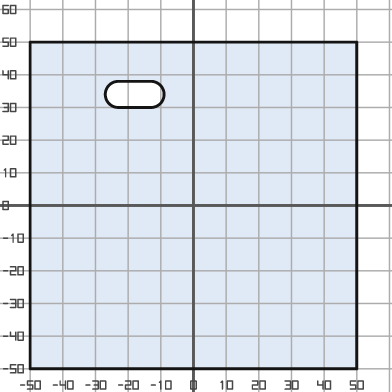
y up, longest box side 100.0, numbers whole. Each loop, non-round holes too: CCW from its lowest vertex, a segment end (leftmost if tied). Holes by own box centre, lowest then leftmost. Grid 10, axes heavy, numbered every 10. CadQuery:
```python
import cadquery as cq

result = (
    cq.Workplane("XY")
    .moveTo(-50.0, -50.0)
    .lineTo(50.0, -50.0)
    .lineTo(50.0, 50.0)
    .lineTo(-50.0, 50.0)
    .close()
    .moveTo(-23.0, 30.0)
    .lineTo(-13.0, 30.0)
    .threePointArc((-9.0, 34.0), (-13.0, 38.0))
    .lineTo(-23.0, 38.0)
    .threePointArc((-27.0, 34.0), (-23.0, 30.0))
    .close()
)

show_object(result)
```